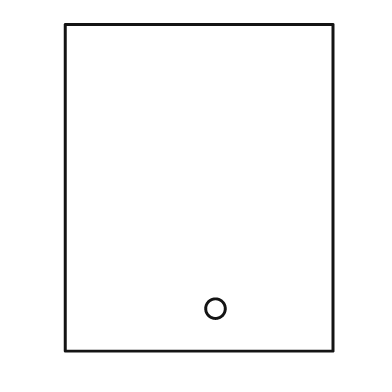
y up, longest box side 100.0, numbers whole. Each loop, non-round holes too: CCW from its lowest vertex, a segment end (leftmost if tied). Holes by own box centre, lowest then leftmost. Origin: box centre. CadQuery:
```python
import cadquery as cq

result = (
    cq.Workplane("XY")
    .moveTo(-41.0, -50.0)
    .lineTo(41.0, -50.0)
    .lineTo(41.0, 50.0)
    .lineTo(-41.0, 50.0)
    .close()
    .moveTo(5.0, -37.0)
    .circle(3.0)
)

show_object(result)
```